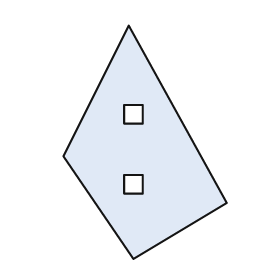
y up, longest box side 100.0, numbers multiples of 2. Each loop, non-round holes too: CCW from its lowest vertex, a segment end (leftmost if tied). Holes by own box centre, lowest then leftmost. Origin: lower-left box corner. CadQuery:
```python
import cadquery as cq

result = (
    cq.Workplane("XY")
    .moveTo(30.0, 0.0)
    .lineTo(70.0, 24.0)
    .lineTo(28.0, 100.0)
    .lineTo(0.0, 44.0)
    .close()
    .moveTo(26.0, 28.0)
    .lineTo(34.0, 28.0)
    .lineTo(34.0, 36.0)
    .lineTo(26.0, 36.0)
    .close()
    .moveTo(26.0, 58.0)
    .lineTo(34.0, 58.0)
    .lineTo(34.0, 66.0)
    .lineTo(26.0, 66.0)
    .close()
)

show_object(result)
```